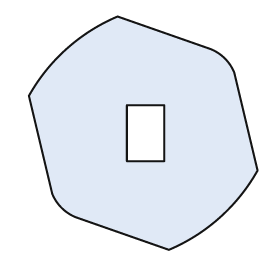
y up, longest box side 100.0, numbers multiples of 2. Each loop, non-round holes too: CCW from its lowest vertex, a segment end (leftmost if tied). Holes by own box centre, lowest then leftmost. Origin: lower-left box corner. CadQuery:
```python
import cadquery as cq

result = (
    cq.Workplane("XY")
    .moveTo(60.0, 0.0)
    .threePointArc((82.0, 14.0), (98.0, 34.0))
    .lineTo(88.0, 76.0)
    .threePointArc((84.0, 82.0), (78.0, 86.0))
    .lineTo(38.0, 100.0)
    .threePointArc((16.0, 86.0), (0.0, 66.0))
    .lineTo(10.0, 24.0)
    .threePointArc((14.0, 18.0), (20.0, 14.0))
    .close()
    .moveTo(42.0, 38.0)
    .lineTo(58.0, 38.0)
    .lineTo(58.0, 62.0)
    .lineTo(42.0, 62.0)
    .close()
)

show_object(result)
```